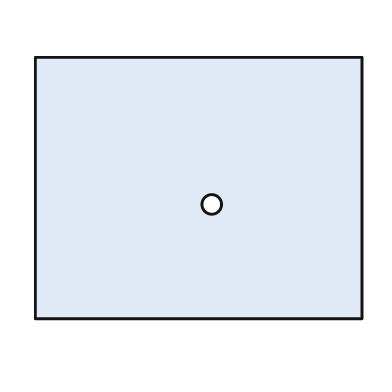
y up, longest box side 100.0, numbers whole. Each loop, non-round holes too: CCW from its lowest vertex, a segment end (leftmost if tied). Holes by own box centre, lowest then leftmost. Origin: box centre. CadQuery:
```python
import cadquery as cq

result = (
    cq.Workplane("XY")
    .moveTo(-50.0, -40.0)
    .lineTo(50.0, -40.0)
    .lineTo(50.0, 40.0)
    .lineTo(-50.0, 40.0)
    .close()
    .moveTo(4.0, -5.0)
    .circle(3.0)
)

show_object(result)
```